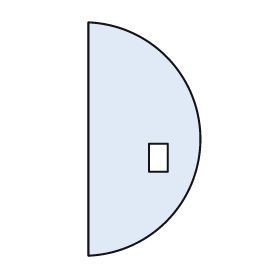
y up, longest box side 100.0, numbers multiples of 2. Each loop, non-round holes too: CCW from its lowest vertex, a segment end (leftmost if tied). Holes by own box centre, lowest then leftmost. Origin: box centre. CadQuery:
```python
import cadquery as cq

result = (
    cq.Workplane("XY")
    .moveTo(-24.0, -50.0)
    .threePointArc((24.0, 0.0), (-24.0, 50.0))
    .close()
    .moveTo(2.0, -14.0)
    .lineTo(10.0, -14.0)
    .lineTo(10.0, -2.0)
    .lineTo(2.0, -2.0)
    .close()
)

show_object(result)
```